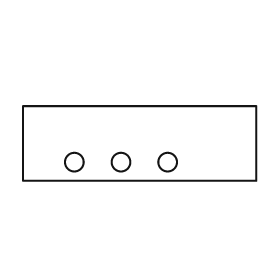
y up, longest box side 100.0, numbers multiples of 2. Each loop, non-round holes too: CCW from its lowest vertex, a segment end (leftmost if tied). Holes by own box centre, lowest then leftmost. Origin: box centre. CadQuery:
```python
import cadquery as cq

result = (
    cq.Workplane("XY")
    .moveTo(-50.0, -16.0)
    .lineTo(50.0, -16.0)
    .lineTo(50.0, 16.0)
    .lineTo(-50.0, 16.0)
    .close()
    .moveTo(-28.0, -8.0)
    .circle(4.0)
    .moveTo(-8.0, -8.0)
    .circle(4.0)
    .moveTo(12.0, -8.0)
    .circle(4.0)
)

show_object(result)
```